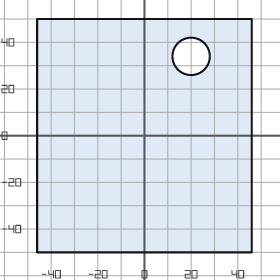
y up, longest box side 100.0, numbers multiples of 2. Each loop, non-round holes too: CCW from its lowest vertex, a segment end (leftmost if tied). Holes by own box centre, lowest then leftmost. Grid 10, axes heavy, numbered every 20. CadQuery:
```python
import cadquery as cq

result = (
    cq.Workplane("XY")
    .moveTo(-46.0, -50.0)
    .lineTo(46.0, -50.0)
    .lineTo(46.0, 50.0)
    .lineTo(-46.0, 50.0)
    .close()
    .moveTo(20.0, 34.0)
    .circle(8.0)
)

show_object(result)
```